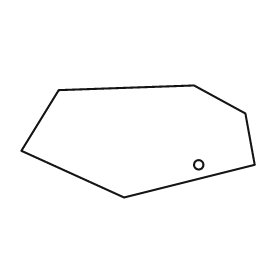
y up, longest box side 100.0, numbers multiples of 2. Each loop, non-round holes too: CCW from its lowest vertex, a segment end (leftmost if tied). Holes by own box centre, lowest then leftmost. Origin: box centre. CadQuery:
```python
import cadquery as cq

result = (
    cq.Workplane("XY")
    .moveTo(-6.0, -24.0)
    .lineTo(50.0, -10.0)
    .lineTo(46.0, 12.0)
    .lineTo(24.0, 24.0)
    .lineTo(-34.0, 22.0)
    .lineTo(-50.0, -4.0)
    .close()
    .moveTo(26.0, -10.0)
    .circle(2.0)
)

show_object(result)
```